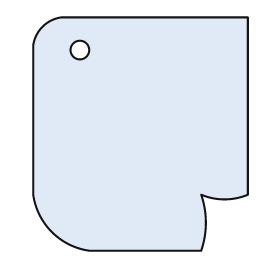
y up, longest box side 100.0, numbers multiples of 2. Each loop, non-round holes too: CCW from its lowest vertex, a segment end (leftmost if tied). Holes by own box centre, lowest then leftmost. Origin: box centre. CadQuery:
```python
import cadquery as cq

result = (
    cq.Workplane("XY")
    .moveTo(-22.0, -50.0)
    .lineTo(26.0, -50.0)
    .threePointArc((28.0, -38.0), (26.0, -26.0))
    .threePointArc((36.0, -28.0), (46.0, -26.0))
    .lineTo(46.0, 50.0)
    .lineTo(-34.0, 50.0)
    .threePointArc((-42.0, 46.0), (-46.0, 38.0))
    .lineTo(-46.0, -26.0)
    .threePointArc((-38.0, -42.0), (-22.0, -50.0))
    .close()
    .moveTo(-26.0, 36.0)
    .circle(4.0)
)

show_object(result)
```